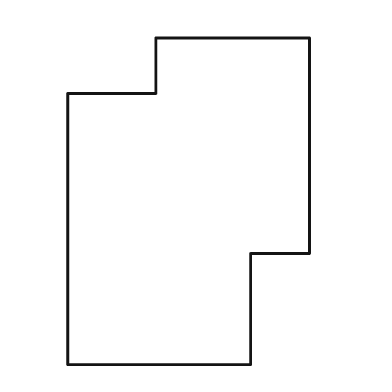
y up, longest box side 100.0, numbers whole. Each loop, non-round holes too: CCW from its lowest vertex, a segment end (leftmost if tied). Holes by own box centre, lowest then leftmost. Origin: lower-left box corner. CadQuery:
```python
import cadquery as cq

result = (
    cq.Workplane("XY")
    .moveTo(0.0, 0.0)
    .lineTo(56.0, 0.0)
    .lineTo(56.0, 34.0)
    .lineTo(74.0, 34.0)
    .lineTo(74.0, 100.0)
    .lineTo(27.0, 100.0)
    .lineTo(27.0, 83.0)
    .lineTo(0.0, 83.0)
    .close()
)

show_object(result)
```